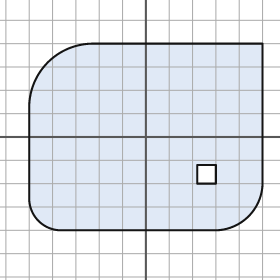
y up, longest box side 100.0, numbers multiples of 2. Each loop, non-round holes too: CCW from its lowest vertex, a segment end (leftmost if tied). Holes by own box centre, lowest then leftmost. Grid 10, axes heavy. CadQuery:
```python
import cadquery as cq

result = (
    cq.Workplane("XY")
    .moveTo(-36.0, -40.0)
    .lineTo(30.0, -40.0)
    .threePointArc((44.0, -34.0), (50.0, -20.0))
    .lineTo(50.0, 40.0)
    .lineTo(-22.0, 40.0)
    .threePointArc((-42.0, 32.0), (-50.0, 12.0))
    .lineTo(-50.0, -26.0)
    .threePointArc((-46.0, -36.0), (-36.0, -40.0))
    .close()
    .moveTo(22.0, -20.0)
    .lineTo(30.0, -20.0)
    .lineTo(30.0, -12.0)
    .lineTo(22.0, -12.0)
    .close()
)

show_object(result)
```